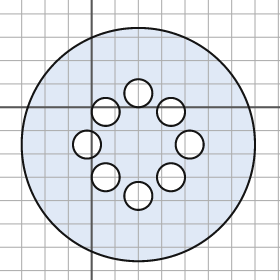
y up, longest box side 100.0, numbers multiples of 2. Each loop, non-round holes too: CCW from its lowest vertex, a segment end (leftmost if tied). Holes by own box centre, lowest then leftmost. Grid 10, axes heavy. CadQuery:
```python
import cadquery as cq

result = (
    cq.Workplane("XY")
    .moveTo(20.0, -16.0)
    .circle(50.0)
    .moveTo(20.0, -38.0)
    .circle(6.0)
    .moveTo(6.0, -30.0)
    .circle(6.0)
    .moveTo(34.0, -30.0)
    .circle(6.0)
    .moveTo(-2.0, -16.0)
    .circle(6.0)
    .moveTo(42.0, -16.0)
    .circle(6.0)
    .moveTo(6.0, -2.0)
    .circle(6.0)
    .moveTo(34.0, -2.0)
    .circle(6.0)
    .moveTo(20.0, 6.0)
    .circle(6.0)
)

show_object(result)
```